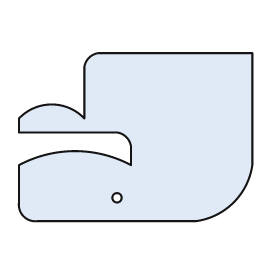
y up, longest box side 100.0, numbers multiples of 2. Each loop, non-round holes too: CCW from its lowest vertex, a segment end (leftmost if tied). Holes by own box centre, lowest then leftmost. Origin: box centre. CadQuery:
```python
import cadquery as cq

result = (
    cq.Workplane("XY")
    .moveTo(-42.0, -36.0)
    .lineTo(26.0, -36.0)
    .threePointArc((42.0, -28.0), (50.0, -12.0))
    .lineTo(50.0, 36.0)
    .lineTo(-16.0, 36.0)
    .threePointArc((-20.0, 34.0), (-22.0, 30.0))
    .lineTo(-22.0, 8.0)
    .threePointArc((-36.0, 14.0), (-50.0, 8.0))
    .lineTo(-50.0, 2.0)
    .lineTo(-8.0, 2.0)
    .threePointArc((-4.0, 0.0), (-2.0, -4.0))
    .lineTo(-2.0, -12.0)
    .threePointArc((-26.0, -6.0), (-50.0, -12.0))
    .lineTo(-50.0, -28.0)
    .threePointArc((-48.0, -34.0), (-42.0, -36.0))
    .close()
    .moveTo(-8.0, -26.0)
    .circle(2.0)
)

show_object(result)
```